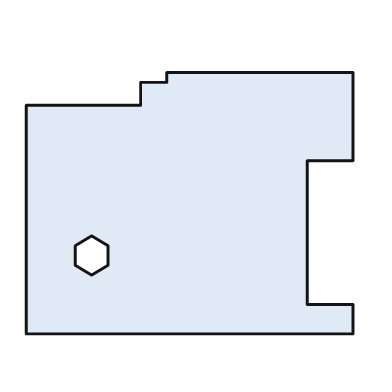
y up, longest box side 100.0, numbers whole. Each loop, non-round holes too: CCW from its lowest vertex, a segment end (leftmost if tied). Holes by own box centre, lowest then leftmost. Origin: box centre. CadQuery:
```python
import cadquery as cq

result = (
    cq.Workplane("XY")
    .moveTo(-50.0, -40.0)
    .lineTo(50.0, -40.0)
    .lineTo(50.0, -31.0)
    .lineTo(36.0, -31.0)
    .lineTo(36.0, 13.0)
    .lineTo(50.0, 13.0)
    .lineTo(50.0, 40.0)
    .lineTo(-7.0, 40.0)
    .lineTo(-7.0, 37.0)
    .lineTo(-15.0, 37.0)
    .lineTo(-15.0, 30.0)
    .lineTo(-50.0, 30.0)
    .close()
    .moveTo(-30.0, -22.0)
    .lineTo(-25.0, -19.0)
    .lineTo(-25.0, -13.0)
    .lineTo(-30.0, -10.0)
    .lineTo(-35.0, -13.0)
    .lineTo(-35.0, -19.0)
    .close()
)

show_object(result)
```